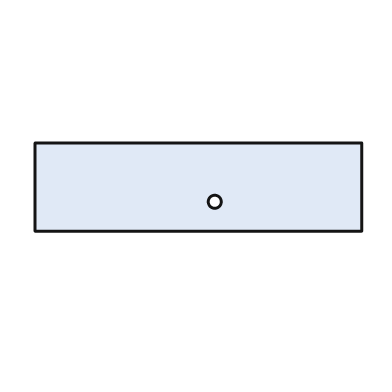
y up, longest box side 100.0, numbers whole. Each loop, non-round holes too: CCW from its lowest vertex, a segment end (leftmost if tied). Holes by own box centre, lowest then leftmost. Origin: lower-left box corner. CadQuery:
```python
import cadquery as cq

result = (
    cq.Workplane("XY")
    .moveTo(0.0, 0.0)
    .lineTo(100.0, 0.0)
    .lineTo(100.0, 27.0)
    .lineTo(0.0, 27.0)
    .close()
    .moveTo(55.0, 9.0)
    .circle(2.0)
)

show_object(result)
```